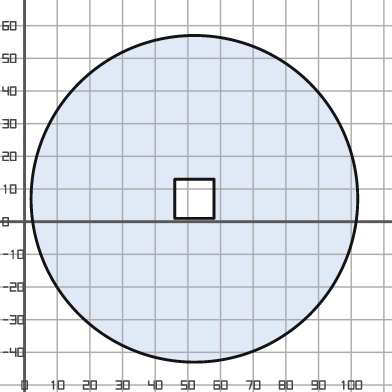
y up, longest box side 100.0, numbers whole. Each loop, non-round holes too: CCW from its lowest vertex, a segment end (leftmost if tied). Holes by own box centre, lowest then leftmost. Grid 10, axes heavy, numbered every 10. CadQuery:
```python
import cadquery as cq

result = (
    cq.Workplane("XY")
    .moveTo(52.0, 7.0)
    .circle(50.0)
    .moveTo(46.0, 1.0)
    .lineTo(58.0, 1.0)
    .lineTo(58.0, 13.0)
    .lineTo(46.0, 13.0)
    .close()
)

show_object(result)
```